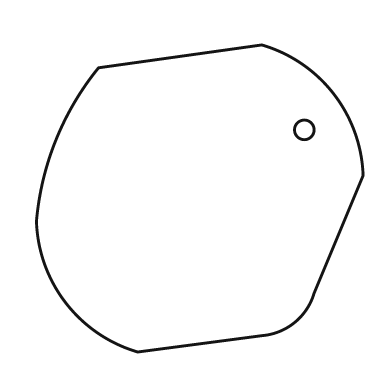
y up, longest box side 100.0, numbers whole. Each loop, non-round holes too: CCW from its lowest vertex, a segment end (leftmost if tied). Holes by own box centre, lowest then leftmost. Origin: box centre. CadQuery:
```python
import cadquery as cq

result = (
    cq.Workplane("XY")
    .moveTo(-19.0, -47.0)
    .lineTo(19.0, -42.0)
    .threePointArc((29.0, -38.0), (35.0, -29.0))
    .lineTo(50.0, 7.0)
    .threePointArc((41.0, 32.0), (19.0, 47.0))
    .lineTo(-31.0, 40.0)
    .threePointArc((-44.0, 18.0), (-50.0, -7.0))
    .threePointArc((-41.0, -32.0), (-19.0, -47.0))
    .close()
    .moveTo(32.0, 21.0)
    .circle(3.0)
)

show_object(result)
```